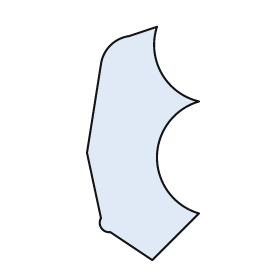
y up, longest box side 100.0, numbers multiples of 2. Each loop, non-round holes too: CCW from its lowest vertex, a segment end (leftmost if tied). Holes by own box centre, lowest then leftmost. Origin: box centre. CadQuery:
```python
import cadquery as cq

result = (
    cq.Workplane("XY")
    .moveTo(4.0, -50.0)
    .lineTo(24.0, -30.0)
    .threePointArc((6.0, -6.0), (24.0, 18.0))
    .threePointArc((8.0, 30.0), (6.0, 50.0))
    .lineTo(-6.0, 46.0)
    .threePointArc((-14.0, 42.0), (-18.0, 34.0))
    .lineTo(-24.0, -4.0)
    .lineTo(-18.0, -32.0)
    .threePointArc((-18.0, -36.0), (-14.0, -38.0))
    .close()
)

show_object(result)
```